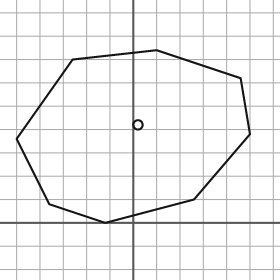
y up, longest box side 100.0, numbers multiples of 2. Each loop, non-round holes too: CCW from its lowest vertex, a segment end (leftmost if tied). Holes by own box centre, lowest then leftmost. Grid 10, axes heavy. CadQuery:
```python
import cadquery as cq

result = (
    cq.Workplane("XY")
    .moveTo(-12.0, 0.0)
    .lineTo(26.0, 10.0)
    .lineTo(50.0, 38.0)
    .lineTo(46.0, 62.0)
    .lineTo(10.0, 74.0)
    .lineTo(-26.0, 70.0)
    .lineTo(-50.0, 36.0)
    .lineTo(-36.0, 8.0)
    .close()
    .moveTo(2.0, 42.0)
    .circle(2.0)
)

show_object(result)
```